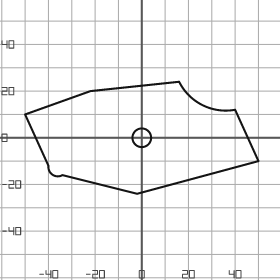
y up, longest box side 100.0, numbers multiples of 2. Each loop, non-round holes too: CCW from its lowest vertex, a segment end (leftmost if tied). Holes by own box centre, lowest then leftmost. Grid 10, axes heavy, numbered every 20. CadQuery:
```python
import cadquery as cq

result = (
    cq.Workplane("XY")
    .moveTo(-2.0, -24.0)
    .lineTo(50.0, -10.0)
    .lineTo(40.0, 12.0)
    .threePointArc((26.0, 14.0), (16.0, 24.0))
    .lineTo(-22.0, 20.0)
    .lineTo(-50.0, 10.0)
    .lineTo(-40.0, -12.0)
    .threePointArc((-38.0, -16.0), (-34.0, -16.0))
    .close()
    .moveTo(0.0, 0.0)
    .circle(4.0)
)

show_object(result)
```